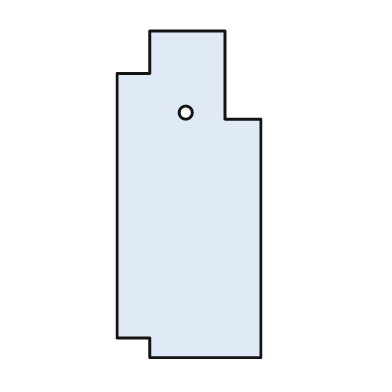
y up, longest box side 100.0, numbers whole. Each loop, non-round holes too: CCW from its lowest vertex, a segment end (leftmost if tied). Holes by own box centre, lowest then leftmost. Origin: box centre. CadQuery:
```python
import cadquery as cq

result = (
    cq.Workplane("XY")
    .moveTo(-12.0, -50.0)
    .lineTo(22.0, -50.0)
    .lineTo(22.0, 23.0)
    .lineTo(11.0, 23.0)
    .lineTo(11.0, 50.0)
    .lineTo(-12.0, 50.0)
    .lineTo(-12.0, 37.0)
    .lineTo(-22.0, 37.0)
    .lineTo(-22.0, -44.0)
    .lineTo(-12.0, -44.0)
    .close()
    .moveTo(-1.0, 25.0)
    .circle(2.0)
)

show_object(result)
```